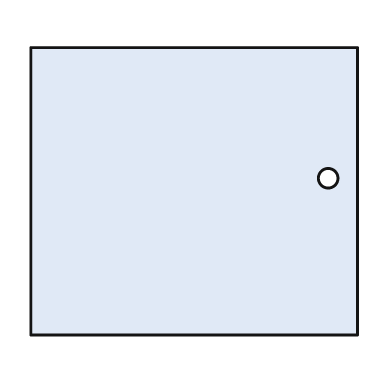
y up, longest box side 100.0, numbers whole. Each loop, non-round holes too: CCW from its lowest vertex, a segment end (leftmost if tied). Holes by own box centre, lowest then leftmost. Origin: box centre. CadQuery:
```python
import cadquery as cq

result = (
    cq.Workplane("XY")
    .moveTo(-50.0, -44.0)
    .lineTo(50.0, -44.0)
    .lineTo(50.0, 44.0)
    .lineTo(-50.0, 44.0)
    .close()
    .moveTo(41.0, 4.0)
    .circle(3.0)
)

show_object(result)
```